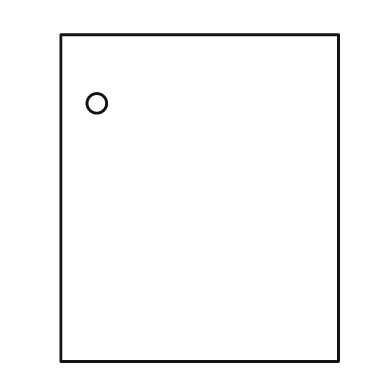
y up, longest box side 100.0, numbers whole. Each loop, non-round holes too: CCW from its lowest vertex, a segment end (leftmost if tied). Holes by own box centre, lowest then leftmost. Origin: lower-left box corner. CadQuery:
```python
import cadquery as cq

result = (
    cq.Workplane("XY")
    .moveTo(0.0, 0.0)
    .lineTo(85.0, 0.0)
    .lineTo(85.0, 100.0)
    .lineTo(0.0, 100.0)
    .close()
    .moveTo(11.0, 79.0)
    .circle(3.0)
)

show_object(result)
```